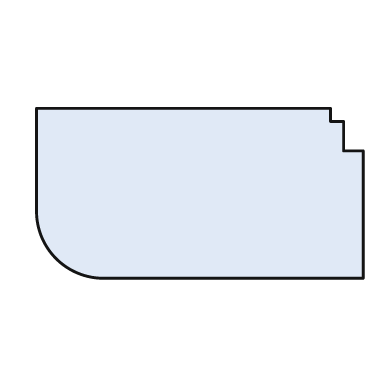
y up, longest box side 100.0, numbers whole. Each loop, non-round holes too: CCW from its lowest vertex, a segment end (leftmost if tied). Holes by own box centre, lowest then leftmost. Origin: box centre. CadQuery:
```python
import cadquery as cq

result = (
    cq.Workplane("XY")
    .moveTo(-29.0, -26.0)
    .lineTo(50.0, -26.0)
    .lineTo(50.0, 13.0)
    .lineTo(44.0, 13.0)
    .lineTo(44.0, 22.0)
    .lineTo(40.0, 22.0)
    .lineTo(40.0, 26.0)
    .lineTo(-50.0, 26.0)
    .lineTo(-50.0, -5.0)
    .threePointArc((-44.0, -20.0), (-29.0, -26.0))
    .close()
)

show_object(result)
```